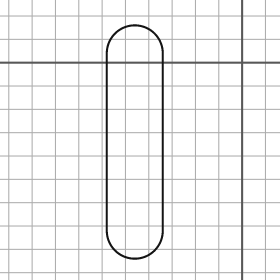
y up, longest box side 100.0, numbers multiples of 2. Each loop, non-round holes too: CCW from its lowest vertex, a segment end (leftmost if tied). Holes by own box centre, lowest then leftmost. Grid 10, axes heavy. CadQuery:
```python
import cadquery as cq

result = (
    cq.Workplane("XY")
    .moveTo(-58.0, -72.0)
    .threePointArc((-46.0, -84.0), (-34.0, -72.0))
    .lineTo(-34.0, 4.0)
    .threePointArc((-46.0, 16.0), (-58.0, 4.0))
    .close()
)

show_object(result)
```